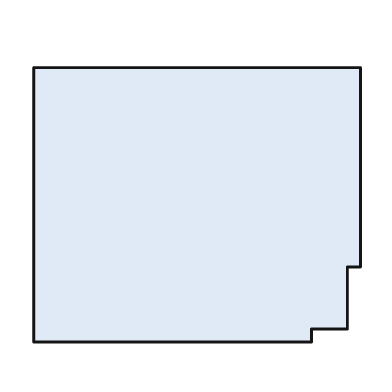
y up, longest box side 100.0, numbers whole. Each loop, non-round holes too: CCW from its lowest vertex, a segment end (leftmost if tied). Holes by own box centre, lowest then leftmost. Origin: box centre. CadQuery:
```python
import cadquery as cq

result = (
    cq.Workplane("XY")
    .moveTo(-50.0, -42.0)
    .lineTo(35.0, -42.0)
    .lineTo(35.0, -38.0)
    .lineTo(46.0, -38.0)
    .lineTo(46.0, -19.0)
    .lineTo(50.0, -19.0)
    .lineTo(50.0, 42.0)
    .lineTo(-50.0, 42.0)
    .close()
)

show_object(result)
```